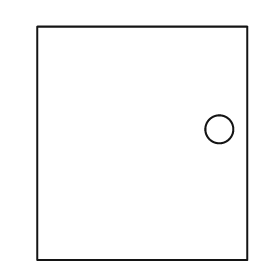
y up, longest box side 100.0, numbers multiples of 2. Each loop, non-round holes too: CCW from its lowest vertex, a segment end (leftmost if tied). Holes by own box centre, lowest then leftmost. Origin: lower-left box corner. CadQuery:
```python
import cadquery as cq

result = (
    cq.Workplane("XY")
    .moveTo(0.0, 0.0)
    .lineTo(90.0, 0.0)
    .lineTo(90.0, 100.0)
    .lineTo(0.0, 100.0)
    .close()
    .moveTo(78.0, 56.0)
    .circle(6.0)
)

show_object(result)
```